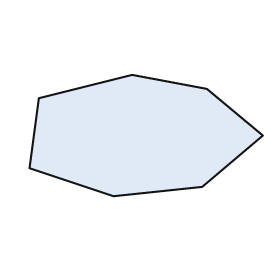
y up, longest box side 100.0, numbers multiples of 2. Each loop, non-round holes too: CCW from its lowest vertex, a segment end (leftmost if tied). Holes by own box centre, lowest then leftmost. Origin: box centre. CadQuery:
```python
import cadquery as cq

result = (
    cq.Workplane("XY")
    .moveTo(-14.0, -26.0)
    .lineTo(24.0, -22.0)
    .lineTo(50.0, 0.0)
    .lineTo(26.0, 20.0)
    .lineTo(-6.0, 26.0)
    .lineTo(-46.0, 16.0)
    .lineTo(-50.0, -14.0)
    .close()
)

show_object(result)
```